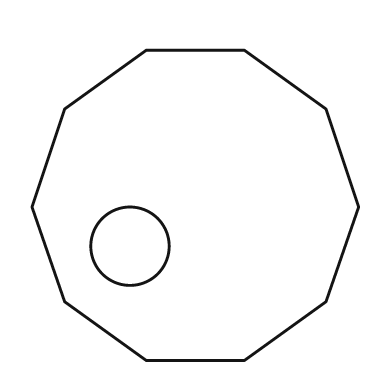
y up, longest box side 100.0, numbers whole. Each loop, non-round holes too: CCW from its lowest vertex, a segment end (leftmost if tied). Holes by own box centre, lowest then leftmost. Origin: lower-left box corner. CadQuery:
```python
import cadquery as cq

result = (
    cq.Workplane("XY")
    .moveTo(35.0, 0.0)
    .lineTo(65.0, 0.0)
    .lineTo(90.0, 18.0)
    .lineTo(100.0, 47.0)
    .lineTo(90.0, 77.0)
    .lineTo(65.0, 95.0)
    .lineTo(35.0, 95.0)
    .lineTo(10.0, 77.0)
    .lineTo(0.0, 47.0)
    .lineTo(10.0, 18.0)
    .close()
    .moveTo(30.0, 35.0)
    .circle(12.0)
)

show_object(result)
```